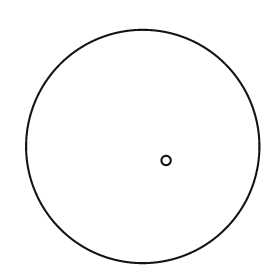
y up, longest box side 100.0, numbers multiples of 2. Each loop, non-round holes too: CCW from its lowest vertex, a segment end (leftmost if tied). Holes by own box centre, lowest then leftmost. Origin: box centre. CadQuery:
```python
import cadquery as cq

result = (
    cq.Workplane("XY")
    .moveTo(0.0, 0.0)
    .circle(50.0)
    .moveTo(10.0, -6.0)
    .circle(2.0)
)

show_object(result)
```